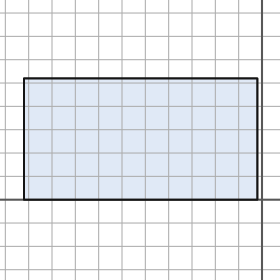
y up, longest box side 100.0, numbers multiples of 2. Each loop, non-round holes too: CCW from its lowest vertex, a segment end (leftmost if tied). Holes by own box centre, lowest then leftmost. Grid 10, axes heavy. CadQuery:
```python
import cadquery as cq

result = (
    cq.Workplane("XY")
    .moveTo(-102.0, 0.0)
    .lineTo(-2.0, 0.0)
    .lineTo(-2.0, 52.0)
    .lineTo(-102.0, 52.0)
    .close()
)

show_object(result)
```